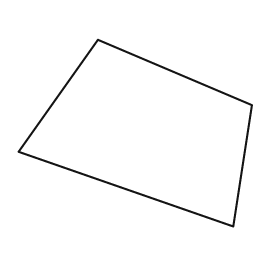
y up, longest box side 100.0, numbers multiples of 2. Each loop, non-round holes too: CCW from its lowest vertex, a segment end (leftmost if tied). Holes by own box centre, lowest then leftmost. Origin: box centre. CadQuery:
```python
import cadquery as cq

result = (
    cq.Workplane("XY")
    .moveTo(42.0, -40.0)
    .lineTo(50.0, 12.0)
    .lineTo(-16.0, 40.0)
    .lineTo(-50.0, -8.0)
    .close()
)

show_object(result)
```